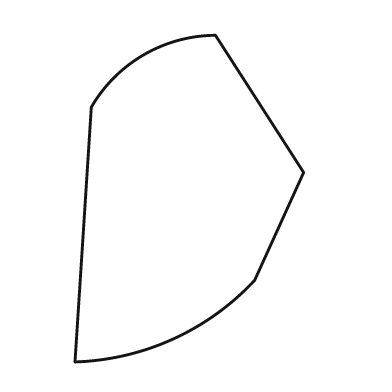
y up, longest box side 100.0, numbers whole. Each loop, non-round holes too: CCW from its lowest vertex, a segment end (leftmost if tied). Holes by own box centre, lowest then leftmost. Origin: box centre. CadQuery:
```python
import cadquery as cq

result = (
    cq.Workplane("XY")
    .moveTo(-35.0, -50.0)
    .threePointArc((-5.0, -43.0), (20.0, -25.0))
    .lineTo(35.0, 8.0)
    .lineTo(8.0, 50.0)
    .threePointArc((-14.0, 44.0), (-30.0, 28.0))
    .close()
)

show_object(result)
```